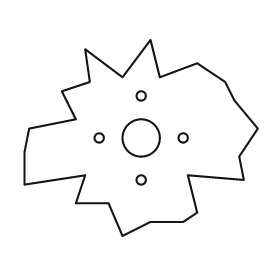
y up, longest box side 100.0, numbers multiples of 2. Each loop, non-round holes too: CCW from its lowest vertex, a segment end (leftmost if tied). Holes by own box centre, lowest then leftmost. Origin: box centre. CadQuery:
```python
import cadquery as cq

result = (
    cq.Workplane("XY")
    .moveTo(-8.0, -42.0)
    .lineTo(4.0, -36.0)
    .lineTo(18.0, -36.0)
    .lineTo(24.0, -32.0)
    .lineTo(20.0, -16.0)
    .lineTo(44.0, -18.0)
    .lineTo(42.0, -8.0)
    .lineTo(50.0, 4.0)
    .lineTo(40.0, 16.0)
    .lineTo(36.0, 24.0)
    .lineTo(24.0, 32.0)
    .lineTo(8.0, 26.0)
    .lineTo(4.0, 42.0)
    .lineTo(-8.0, 26.0)
    .lineTo(-24.0, 38.0)
    .lineTo(-22.0, 24.0)
    .lineTo(-34.0, 20.0)
    .lineTo(-28.0, 8.0)
    .lineTo(-48.0, 4.0)
    .lineTo(-50.0, -6.0)
    .lineTo(-50.0, -20.0)
    .lineTo(-24.0, -16.0)
    .lineTo(-28.0, -28.0)
    .lineTo(-14.0, -28.0)
    .close()
    .moveTo(0.0, -18.0)
    .circle(2.0)
    .moveTo(-18.0, 0.0)
    .circle(2.0)
    .moveTo(0.0, 0.0)
    .circle(8.0)
    .moveTo(18.0, 0.0)
    .circle(2.0)
    .moveTo(0.0, 18.0)
    .circle(2.0)
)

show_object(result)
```